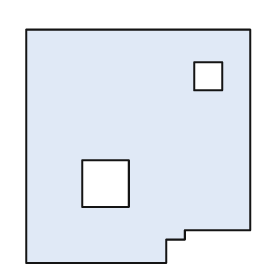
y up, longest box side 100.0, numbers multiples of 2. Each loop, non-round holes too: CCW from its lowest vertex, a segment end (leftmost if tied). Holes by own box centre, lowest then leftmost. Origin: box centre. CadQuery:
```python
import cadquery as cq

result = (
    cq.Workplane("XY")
    .moveTo(-48.0, -50.0)
    .lineTo(12.0, -50.0)
    .lineTo(12.0, -40.0)
    .lineTo(20.0, -40.0)
    .lineTo(20.0, -36.0)
    .lineTo(48.0, -36.0)
    .lineTo(48.0, 50.0)
    .lineTo(-48.0, 50.0)
    .close()
    .moveTo(-24.0, -26.0)
    .lineTo(-4.0, -26.0)
    .lineTo(-4.0, -6.0)
    .lineTo(-24.0, -6.0)
    .close()
    .moveTo(24.0, 24.0)
    .lineTo(36.0, 24.0)
    .lineTo(36.0, 36.0)
    .lineTo(24.0, 36.0)
    .close()
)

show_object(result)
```